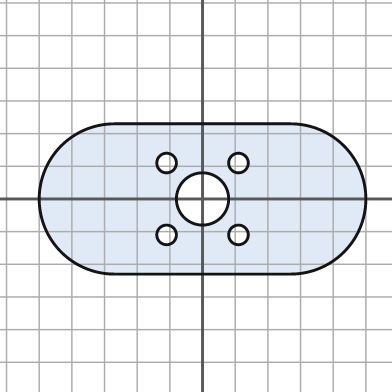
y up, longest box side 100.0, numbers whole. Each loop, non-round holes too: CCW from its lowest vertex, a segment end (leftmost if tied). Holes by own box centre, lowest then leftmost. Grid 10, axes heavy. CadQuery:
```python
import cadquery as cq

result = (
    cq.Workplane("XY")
    .moveTo(-27.0, -23.0)
    .lineTo(27.0, -23.0)
    .threePointArc((50.0, 0.0), (27.0, 23.0))
    .lineTo(-27.0, 23.0)
    .threePointArc((-50.0, 0.0), (-27.0, -23.0))
    .close()
    .moveTo(-11.0, -11.0)
    .circle(3.0)
    .moveTo(11.0, -11.0)
    .circle(3.0)
    .moveTo(0.0, 0.0)
    .circle(8.0)
    .moveTo(-11.0, 11.0)
    .circle(3.0)
    .moveTo(11.0, 11.0)
    .circle(3.0)
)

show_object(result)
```